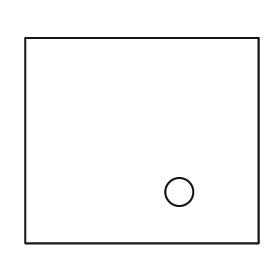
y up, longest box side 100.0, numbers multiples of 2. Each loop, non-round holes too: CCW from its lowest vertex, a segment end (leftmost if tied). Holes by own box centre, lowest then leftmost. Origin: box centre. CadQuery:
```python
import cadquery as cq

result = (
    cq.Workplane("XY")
    .moveTo(-50.0, -44.0)
    .lineTo(50.0, -44.0)
    .lineTo(50.0, 44.0)
    .lineTo(-50.0, 44.0)
    .close()
    .moveTo(16.0, -22.0)
    .circle(6.0)
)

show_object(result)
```